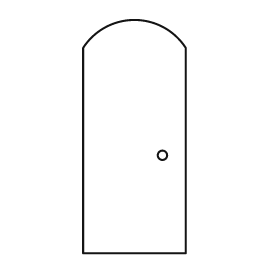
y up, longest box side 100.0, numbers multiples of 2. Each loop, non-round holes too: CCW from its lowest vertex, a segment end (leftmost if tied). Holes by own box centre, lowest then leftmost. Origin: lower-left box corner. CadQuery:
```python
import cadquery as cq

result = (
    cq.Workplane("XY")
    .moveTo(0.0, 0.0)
    .lineTo(44.0, 0.0)
    .lineTo(44.0, 88.0)
    .threePointArc((22.0, 100.0), (0.0, 88.0))
    .close()
    .moveTo(34.0, 42.0)
    .circle(2.0)
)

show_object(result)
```